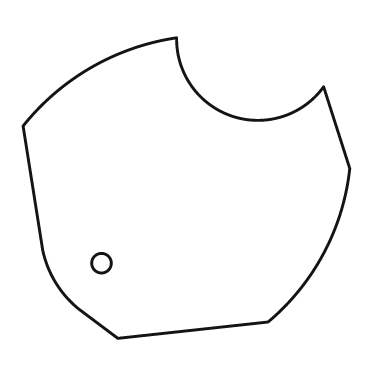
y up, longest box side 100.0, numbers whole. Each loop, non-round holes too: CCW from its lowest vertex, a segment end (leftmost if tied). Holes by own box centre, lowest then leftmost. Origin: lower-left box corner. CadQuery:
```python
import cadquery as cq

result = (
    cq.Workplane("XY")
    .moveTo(29.0, 0.0)
    .lineTo(75.0, 5.0)
    .threePointArc((92.0, 26.0), (100.0, 52.0))
    .lineTo(92.0, 77.0)
    .threePointArc((64.0, 68.0), (47.0, 92.0))
    .threePointArc((21.0, 83.0), (0.0, 65.0))
    .lineTo(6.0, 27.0)
    .threePointArc((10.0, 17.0), (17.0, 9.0))
    .close()
    .moveTo(24.0, 23.0)
    .circle(3.0)
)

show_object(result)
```